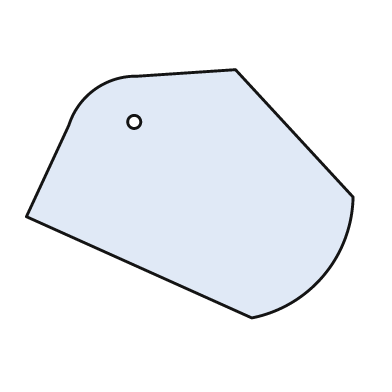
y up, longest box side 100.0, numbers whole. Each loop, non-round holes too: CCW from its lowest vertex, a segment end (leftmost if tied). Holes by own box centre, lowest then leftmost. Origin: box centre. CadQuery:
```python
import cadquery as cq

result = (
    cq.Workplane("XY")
    .moveTo(19.0, -38.0)
    .threePointArc((41.0, -25.0), (50.0, -1.0))
    .lineTo(14.0, 38.0)
    .lineTo(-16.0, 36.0)
    .threePointArc((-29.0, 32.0), (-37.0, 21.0))
    .lineTo(-50.0, -7.0)
    .close()
    .moveTo(-17.0, 22.0)
    .circle(2.0)
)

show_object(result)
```